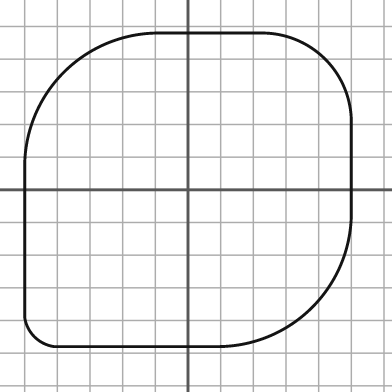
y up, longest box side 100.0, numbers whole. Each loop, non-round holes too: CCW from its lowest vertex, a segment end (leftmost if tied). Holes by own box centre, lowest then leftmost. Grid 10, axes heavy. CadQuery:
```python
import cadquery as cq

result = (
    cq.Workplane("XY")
    .moveTo(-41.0, -48.0)
    .lineTo(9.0, -48.0)
    .threePointArc((38.0, -36.0), (50.0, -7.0))
    .lineTo(50.0, 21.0)
    .threePointArc((42.0, 40.0), (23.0, 48.0))
    .lineTo(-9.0, 48.0)
    .threePointArc((-38.0, 36.0), (-50.0, 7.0))
    .lineTo(-50.0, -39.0)
    .threePointArc((-47.0, -45.0), (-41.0, -48.0))
    .close()
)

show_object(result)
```